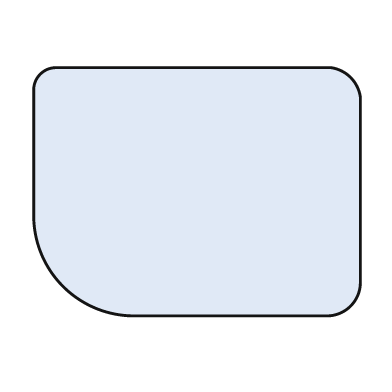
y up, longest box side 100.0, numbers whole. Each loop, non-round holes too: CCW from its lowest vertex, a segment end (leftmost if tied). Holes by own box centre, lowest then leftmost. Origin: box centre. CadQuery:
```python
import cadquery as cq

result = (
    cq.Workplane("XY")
    .moveTo(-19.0, -38.0)
    .lineTo(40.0, -38.0)
    .threePointArc((47.0, -35.0), (50.0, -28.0))
    .lineTo(50.0, 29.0)
    .threePointArc((47.0, 35.0), (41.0, 38.0))
    .lineTo(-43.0, 38.0)
    .threePointArc((-48.0, 36.0), (-50.0, 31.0))
    .lineTo(-50.0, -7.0)
    .threePointArc((-41.0, -29.0), (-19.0, -38.0))
    .close()
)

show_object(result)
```